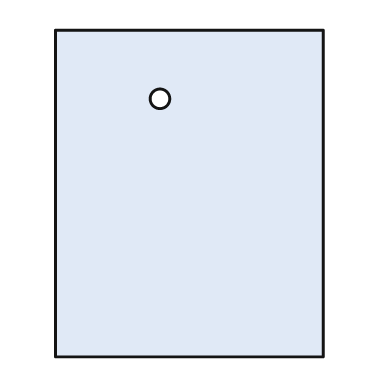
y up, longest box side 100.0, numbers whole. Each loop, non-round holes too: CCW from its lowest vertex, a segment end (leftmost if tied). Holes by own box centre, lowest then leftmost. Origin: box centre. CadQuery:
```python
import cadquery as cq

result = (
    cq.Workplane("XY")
    .moveTo(-41.0, -50.0)
    .lineTo(41.0, -50.0)
    .lineTo(41.0, 50.0)
    .lineTo(-41.0, 50.0)
    .close()
    .moveTo(-9.0, 29.0)
    .circle(3.0)
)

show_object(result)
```